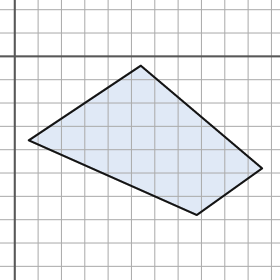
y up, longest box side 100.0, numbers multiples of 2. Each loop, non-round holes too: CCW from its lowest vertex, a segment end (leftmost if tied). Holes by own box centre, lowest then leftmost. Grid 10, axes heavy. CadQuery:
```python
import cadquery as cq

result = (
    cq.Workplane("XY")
    .moveTo(78.0, -68.0)
    .lineTo(106.0, -48.0)
    .lineTo(54.0, -4.0)
    .lineTo(6.0, -36.0)
    .close()
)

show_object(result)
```